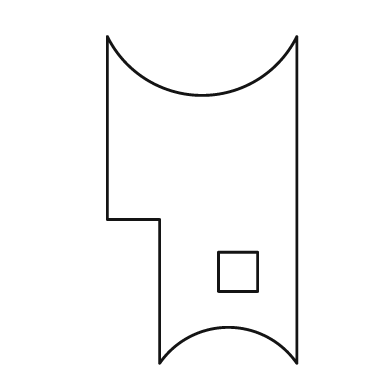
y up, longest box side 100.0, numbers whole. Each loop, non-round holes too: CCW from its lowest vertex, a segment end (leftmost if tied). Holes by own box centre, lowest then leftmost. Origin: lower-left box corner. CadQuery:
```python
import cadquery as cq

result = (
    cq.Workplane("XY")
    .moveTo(16.0, 0.0)
    .threePointArc((37.0, 11.0), (58.0, 0.0))
    .lineTo(58.0, 100.0)
    .threePointArc((29.0, 82.0), (0.0, 100.0))
    .lineTo(0.0, 44.0)
    .lineTo(16.0, 44.0)
    .close()
    .moveTo(34.0, 22.0)
    .lineTo(46.0, 22.0)
    .lineTo(46.0, 34.0)
    .lineTo(34.0, 34.0)
    .close()
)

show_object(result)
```